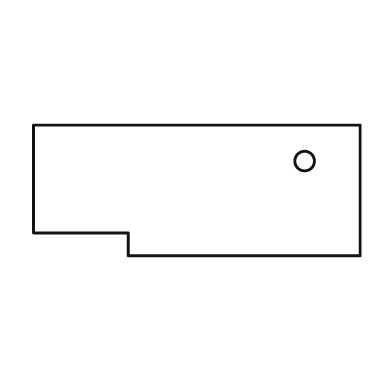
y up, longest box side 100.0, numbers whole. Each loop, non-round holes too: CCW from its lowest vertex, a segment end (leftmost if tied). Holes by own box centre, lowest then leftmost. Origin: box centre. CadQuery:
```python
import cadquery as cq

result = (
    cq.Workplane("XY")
    .moveTo(-21.0, -20.0)
    .lineTo(50.0, -20.0)
    .lineTo(50.0, 20.0)
    .lineTo(-50.0, 20.0)
    .lineTo(-50.0, -13.0)
    .lineTo(-21.0, -13.0)
    .close()
    .moveTo(33.0, 9.0)
    .circle(3.0)
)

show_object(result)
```